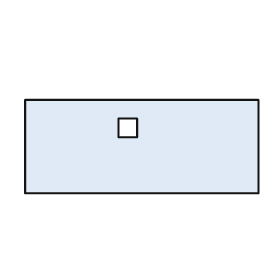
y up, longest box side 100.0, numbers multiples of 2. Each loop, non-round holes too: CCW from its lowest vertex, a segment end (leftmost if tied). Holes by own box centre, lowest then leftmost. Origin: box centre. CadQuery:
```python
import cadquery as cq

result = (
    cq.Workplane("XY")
    .moveTo(-50.0, -20.0)
    .lineTo(50.0, -20.0)
    .lineTo(50.0, 20.0)
    .lineTo(-50.0, 20.0)
    .close()
    .moveTo(-10.0, 4.0)
    .lineTo(-2.0, 4.0)
    .lineTo(-2.0, 12.0)
    .lineTo(-10.0, 12.0)
    .close()
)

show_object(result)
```